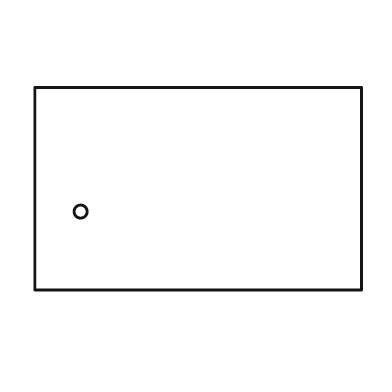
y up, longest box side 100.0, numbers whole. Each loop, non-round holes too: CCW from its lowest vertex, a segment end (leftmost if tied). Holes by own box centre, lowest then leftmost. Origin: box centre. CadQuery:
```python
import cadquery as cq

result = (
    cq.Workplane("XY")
    .moveTo(-50.0, -31.0)
    .lineTo(50.0, -31.0)
    .lineTo(50.0, 31.0)
    .lineTo(-50.0, 31.0)
    .close()
    .moveTo(-36.0, -7.0)
    .circle(2.0)
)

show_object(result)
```